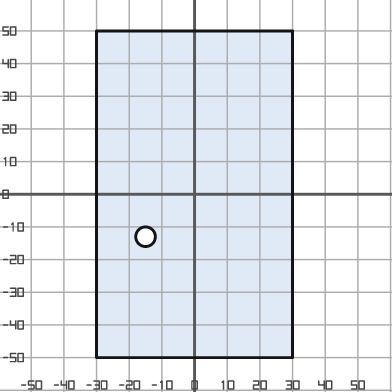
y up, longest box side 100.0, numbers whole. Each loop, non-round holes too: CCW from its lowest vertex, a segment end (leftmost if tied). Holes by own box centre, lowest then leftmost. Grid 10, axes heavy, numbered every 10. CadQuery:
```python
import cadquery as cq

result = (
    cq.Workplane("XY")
    .moveTo(-30.0, -50.0)
    .lineTo(30.0, -50.0)
    .lineTo(30.0, 50.0)
    .lineTo(-30.0, 50.0)
    .close()
    .moveTo(-15.0, -13.0)
    .circle(3.0)
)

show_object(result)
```